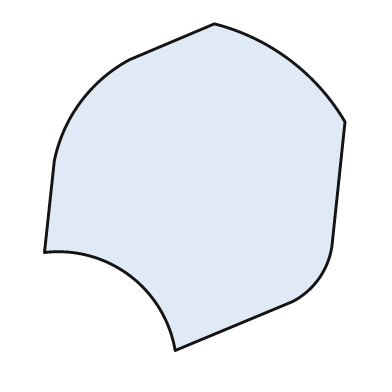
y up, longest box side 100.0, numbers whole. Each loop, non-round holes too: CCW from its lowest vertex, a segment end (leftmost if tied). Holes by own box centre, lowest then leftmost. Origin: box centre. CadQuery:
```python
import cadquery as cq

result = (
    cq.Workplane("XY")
    .moveTo(-6.0, -50.0)
    .lineTo(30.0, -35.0)
    .threePointArc((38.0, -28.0), (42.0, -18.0))
    .lineTo(46.0, 20.0)
    .threePointArc((29.0, 39.0), (6.0, 50.0))
    .lineTo(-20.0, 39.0)
    .threePointArc((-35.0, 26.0), (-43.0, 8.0))
    .lineTo(-46.0, -20.0)
    .threePointArc((-20.0, -27.0), (-6.0, -50.0))
    .close()
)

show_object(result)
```